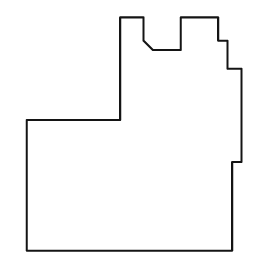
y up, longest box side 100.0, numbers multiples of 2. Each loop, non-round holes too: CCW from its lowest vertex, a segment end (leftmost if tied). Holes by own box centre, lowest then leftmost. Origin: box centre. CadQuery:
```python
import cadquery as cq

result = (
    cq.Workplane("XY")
    .moveTo(-46.0, -50.0)
    .lineTo(42.0, -50.0)
    .lineTo(42.0, -12.0)
    .lineTo(46.0, -12.0)
    .lineTo(46.0, 28.0)
    .lineTo(40.0, 28.0)
    .lineTo(40.0, 40.0)
    .lineTo(36.0, 40.0)
    .lineTo(36.0, 50.0)
    .lineTo(20.0, 50.0)
    .lineTo(20.0, 36.0)
    .lineTo(8.0, 36.0)
    .lineTo(4.0, 40.0)
    .lineTo(4.0, 50.0)
    .lineTo(-6.0, 50.0)
    .lineTo(-6.0, 6.0)
    .lineTo(-46.0, 6.0)
    .close()
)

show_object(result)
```